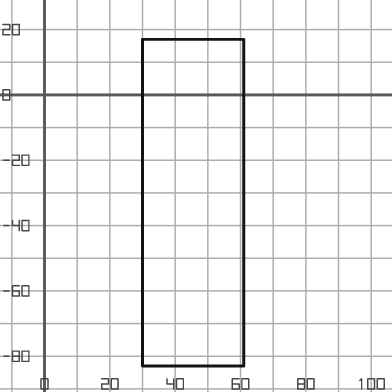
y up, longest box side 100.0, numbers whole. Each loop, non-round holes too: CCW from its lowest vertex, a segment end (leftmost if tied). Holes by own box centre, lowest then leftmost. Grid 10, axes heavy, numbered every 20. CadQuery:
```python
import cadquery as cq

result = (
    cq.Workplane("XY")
    .moveTo(30.0, -83.0)
    .lineTo(61.0, -83.0)
    .lineTo(61.0, 17.0)
    .lineTo(30.0, 17.0)
    .close()
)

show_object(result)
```